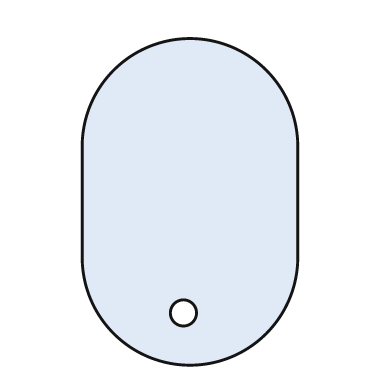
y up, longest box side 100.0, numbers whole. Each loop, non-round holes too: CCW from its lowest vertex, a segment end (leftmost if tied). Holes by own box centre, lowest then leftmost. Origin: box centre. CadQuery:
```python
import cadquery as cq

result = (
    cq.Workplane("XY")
    .moveTo(-33.0, -17.0)
    .threePointArc((0.0, -50.0), (33.0, -17.0))
    .lineTo(33.0, 17.0)
    .threePointArc((0.0, 50.0), (-33.0, 17.0))
    .close()
    .moveTo(-2.0, -34.0)
    .circle(4.0)
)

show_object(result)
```